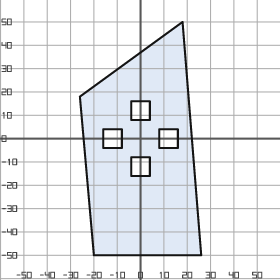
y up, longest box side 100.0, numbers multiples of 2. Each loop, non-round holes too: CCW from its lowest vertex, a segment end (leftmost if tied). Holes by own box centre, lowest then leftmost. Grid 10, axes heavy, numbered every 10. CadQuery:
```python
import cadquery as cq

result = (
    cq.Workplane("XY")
    .moveTo(-20.0, -50.0)
    .lineTo(26.0, -50.0)
    .lineTo(18.0, 50.0)
    .lineTo(-26.0, 18.0)
    .close()
    .moveTo(-4.0, -16.0)
    .lineTo(4.0, -16.0)
    .lineTo(4.0, -8.0)
    .lineTo(-4.0, -8.0)
    .close()
    .moveTo(-16.0, -4.0)
    .lineTo(-8.0, -4.0)
    .lineTo(-8.0, 4.0)
    .lineTo(-16.0, 4.0)
    .close()
    .moveTo(8.0, -4.0)
    .lineTo(16.0, -4.0)
    .lineTo(16.0, 4.0)
    .lineTo(8.0, 4.0)
    .close()
    .moveTo(-4.0, 8.0)
    .lineTo(4.0, 8.0)
    .lineTo(4.0, 16.0)
    .lineTo(-4.0, 16.0)
    .close()
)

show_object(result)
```